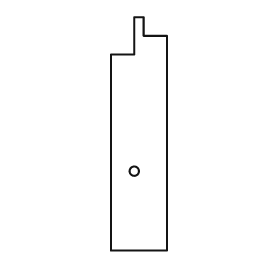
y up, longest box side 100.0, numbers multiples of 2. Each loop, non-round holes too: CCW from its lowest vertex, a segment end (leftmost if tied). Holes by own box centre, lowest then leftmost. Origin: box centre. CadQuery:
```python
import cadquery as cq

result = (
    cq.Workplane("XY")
    .moveTo(-12.0, -50.0)
    .lineTo(12.0, -50.0)
    .lineTo(12.0, 42.0)
    .lineTo(2.0, 42.0)
    .lineTo(2.0, 50.0)
    .lineTo(-2.0, 50.0)
    .lineTo(-2.0, 34.0)
    .lineTo(-12.0, 34.0)
    .close()
    .moveTo(-2.0, -16.0)
    .circle(2.0)
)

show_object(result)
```